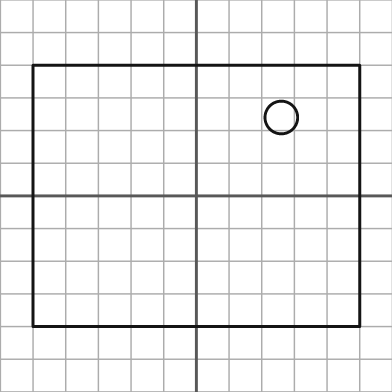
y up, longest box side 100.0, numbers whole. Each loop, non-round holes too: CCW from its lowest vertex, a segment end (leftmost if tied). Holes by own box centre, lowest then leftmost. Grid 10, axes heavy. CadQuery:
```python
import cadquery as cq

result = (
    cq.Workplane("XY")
    .moveTo(-50.0, -40.0)
    .lineTo(50.0, -40.0)
    .lineTo(50.0, 40.0)
    .lineTo(-50.0, 40.0)
    .close()
    .moveTo(26.0, 24.0)
    .circle(5.0)
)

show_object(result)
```